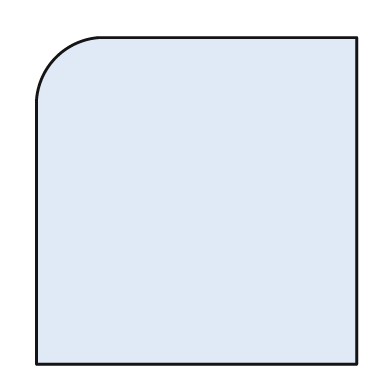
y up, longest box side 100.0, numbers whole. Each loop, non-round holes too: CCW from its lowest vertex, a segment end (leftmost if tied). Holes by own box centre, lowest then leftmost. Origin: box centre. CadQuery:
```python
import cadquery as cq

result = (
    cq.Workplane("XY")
    .moveTo(-49.0, -50.0)
    .lineTo(49.0, -50.0)
    .lineTo(49.0, 50.0)
    .lineTo(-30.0, 50.0)
    .threePointArc((-43.0, 44.0), (-49.0, 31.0))
    .close()
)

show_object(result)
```